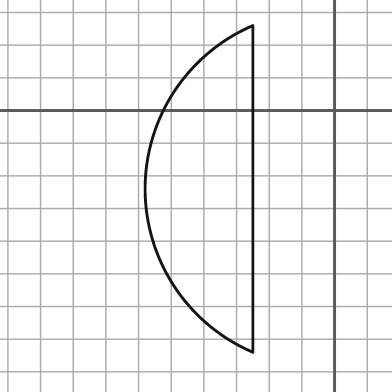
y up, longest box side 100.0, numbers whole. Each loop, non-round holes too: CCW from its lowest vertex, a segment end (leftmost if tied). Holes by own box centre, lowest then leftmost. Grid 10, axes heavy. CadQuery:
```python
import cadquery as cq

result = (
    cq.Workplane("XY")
    .moveTo(-25.0, -74.0)
    .lineTo(-25.0, 26.0)
    .threePointArc((-58.0, -24.0), (-25.0, -74.0))
    .close()
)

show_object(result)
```